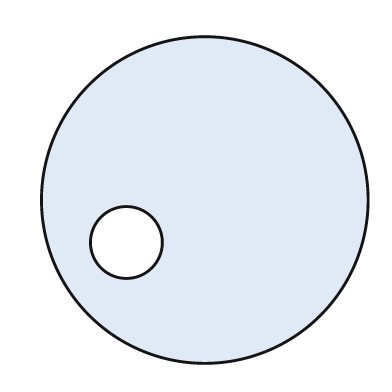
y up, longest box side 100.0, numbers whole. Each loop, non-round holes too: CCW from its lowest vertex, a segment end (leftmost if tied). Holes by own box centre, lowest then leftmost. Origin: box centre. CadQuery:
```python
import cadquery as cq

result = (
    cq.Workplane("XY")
    .moveTo(0.0, 0.0)
    .circle(50.0)
    .moveTo(-24.0, -13.0)
    .circle(11.0)
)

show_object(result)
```